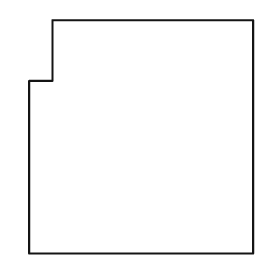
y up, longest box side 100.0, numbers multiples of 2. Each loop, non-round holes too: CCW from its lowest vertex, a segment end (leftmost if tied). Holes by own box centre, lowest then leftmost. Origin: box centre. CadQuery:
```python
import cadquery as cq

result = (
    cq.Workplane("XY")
    .moveTo(-48.0, -50.0)
    .lineTo(48.0, -50.0)
    .lineTo(48.0, 50.0)
    .lineTo(-38.0, 50.0)
    .lineTo(-38.0, 24.0)
    .lineTo(-48.0, 24.0)
    .close()
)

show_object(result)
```